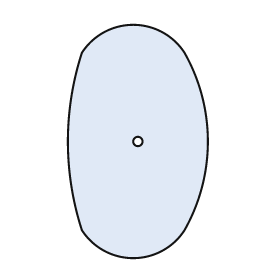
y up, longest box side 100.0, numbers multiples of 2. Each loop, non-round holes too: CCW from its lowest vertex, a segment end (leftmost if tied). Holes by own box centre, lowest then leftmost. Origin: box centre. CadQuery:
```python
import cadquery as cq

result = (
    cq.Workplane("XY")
    .moveTo(-24.0, -38.0)
    .threePointArc((-2.0, -50.0), (20.0, -38.0))
    .threePointArc((30.0, 0.0), (20.0, 38.0))
    .threePointArc((-2.0, 50.0), (-24.0, 38.0))
    .threePointArc((-30.0, 0.0), (-24.0, -38.0))
    .close()
    .moveTo(0.0, 0.0)
    .circle(2.0)
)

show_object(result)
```